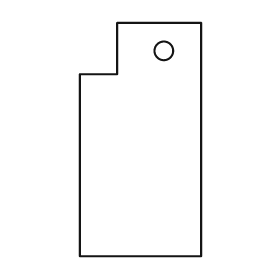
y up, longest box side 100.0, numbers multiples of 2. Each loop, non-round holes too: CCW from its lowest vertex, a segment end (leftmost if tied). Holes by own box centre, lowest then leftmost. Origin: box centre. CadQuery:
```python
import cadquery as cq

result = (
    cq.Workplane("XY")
    .moveTo(-26.0, -50.0)
    .lineTo(26.0, -50.0)
    .lineTo(26.0, 50.0)
    .lineTo(-10.0, 50.0)
    .lineTo(-10.0, 28.0)
    .lineTo(-26.0, 28.0)
    .close()
    .moveTo(10.0, 38.0)
    .circle(4.0)
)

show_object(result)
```